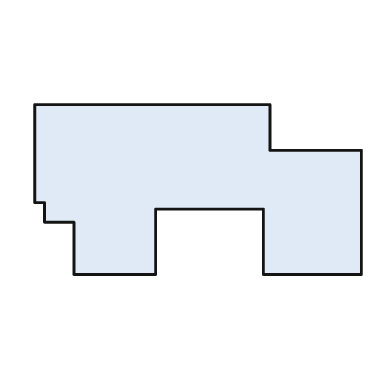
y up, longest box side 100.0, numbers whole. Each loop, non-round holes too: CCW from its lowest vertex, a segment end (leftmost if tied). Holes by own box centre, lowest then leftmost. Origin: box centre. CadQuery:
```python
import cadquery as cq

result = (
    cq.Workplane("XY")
    .moveTo(-38.0, -26.0)
    .lineTo(-13.0, -26.0)
    .lineTo(-13.0, -6.0)
    .lineTo(20.0, -6.0)
    .lineTo(20.0, -26.0)
    .lineTo(50.0, -26.0)
    .lineTo(50.0, 12.0)
    .lineTo(22.0, 12.0)
    .lineTo(22.0, 26.0)
    .lineTo(-50.0, 26.0)
    .lineTo(-50.0, -4.0)
    .lineTo(-47.0, -4.0)
    .lineTo(-47.0, -10.0)
    .lineTo(-38.0, -10.0)
    .close()
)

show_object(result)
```